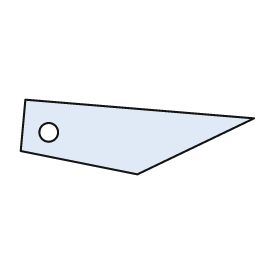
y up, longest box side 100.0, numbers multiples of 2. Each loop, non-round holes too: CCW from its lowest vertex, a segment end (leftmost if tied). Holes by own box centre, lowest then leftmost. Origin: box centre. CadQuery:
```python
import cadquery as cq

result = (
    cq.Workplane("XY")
    .moveTo(0.0, -16.0)
    .lineTo(50.0, 8.0)
    .lineTo(-48.0, 16.0)
    .lineTo(-50.0, -6.0)
    .close()
    .moveTo(-38.0, 2.0)
    .circle(4.0)
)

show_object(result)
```